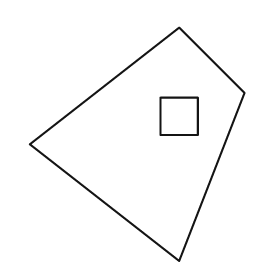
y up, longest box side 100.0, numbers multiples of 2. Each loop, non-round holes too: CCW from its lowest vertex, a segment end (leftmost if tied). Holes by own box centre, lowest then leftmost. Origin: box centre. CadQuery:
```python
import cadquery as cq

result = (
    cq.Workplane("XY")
    .moveTo(18.0, -50.0)
    .lineTo(46.0, 22.0)
    .lineTo(18.0, 50.0)
    .lineTo(-46.0, 0.0)
    .close()
    .moveTo(10.0, 4.0)
    .lineTo(26.0, 4.0)
    .lineTo(26.0, 20.0)
    .lineTo(10.0, 20.0)
    .close()
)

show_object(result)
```